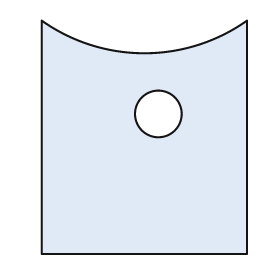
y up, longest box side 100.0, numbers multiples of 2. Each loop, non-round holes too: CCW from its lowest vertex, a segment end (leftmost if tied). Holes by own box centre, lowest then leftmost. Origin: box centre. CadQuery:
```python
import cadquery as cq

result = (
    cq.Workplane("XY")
    .moveTo(-44.0, -50.0)
    .lineTo(44.0, -50.0)
    .lineTo(44.0, 50.0)
    .threePointArc((0.0, 36.0), (-44.0, 50.0))
    .close()
    .moveTo(6.0, 10.0)
    .circle(10.0)
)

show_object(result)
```